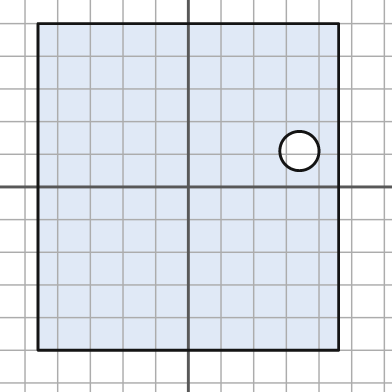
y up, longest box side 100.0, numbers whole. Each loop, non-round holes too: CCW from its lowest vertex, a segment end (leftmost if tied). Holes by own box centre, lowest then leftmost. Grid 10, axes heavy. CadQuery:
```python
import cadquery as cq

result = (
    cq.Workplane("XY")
    .moveTo(-46.0, -50.0)
    .lineTo(46.0, -50.0)
    .lineTo(46.0, 50.0)
    .lineTo(-46.0, 50.0)
    .close()
    .moveTo(34.0, 11.0)
    .circle(6.0)
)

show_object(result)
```